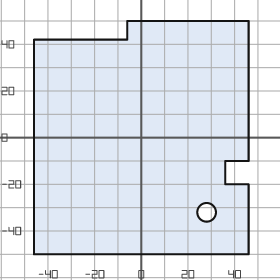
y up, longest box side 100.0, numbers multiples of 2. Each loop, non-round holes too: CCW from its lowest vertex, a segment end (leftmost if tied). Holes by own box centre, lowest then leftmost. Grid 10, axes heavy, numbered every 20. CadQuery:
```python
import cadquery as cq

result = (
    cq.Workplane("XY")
    .moveTo(-46.0, -50.0)
    .lineTo(46.0, -50.0)
    .lineTo(46.0, -20.0)
    .lineTo(36.0, -20.0)
    .lineTo(36.0, -10.0)
    .lineTo(46.0, -10.0)
    .lineTo(46.0, 50.0)
    .lineTo(-6.0, 50.0)
    .lineTo(-6.0, 42.0)
    .lineTo(-46.0, 42.0)
    .close()
    .moveTo(28.0, -32.0)
    .circle(4.0)
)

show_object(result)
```